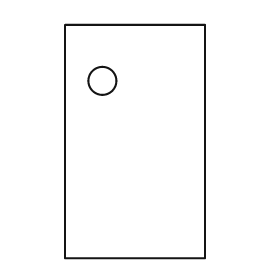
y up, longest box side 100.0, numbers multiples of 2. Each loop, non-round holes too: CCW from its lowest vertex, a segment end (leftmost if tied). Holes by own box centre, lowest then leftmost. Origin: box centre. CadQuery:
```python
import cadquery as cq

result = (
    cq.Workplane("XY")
    .moveTo(-30.0, -50.0)
    .lineTo(30.0, -50.0)
    .lineTo(30.0, 50.0)
    .lineTo(-30.0, 50.0)
    .close()
    .moveTo(-14.0, 26.0)
    .circle(6.0)
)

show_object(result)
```